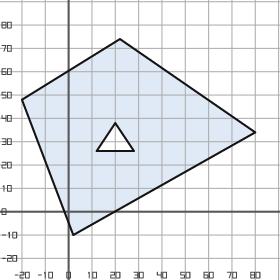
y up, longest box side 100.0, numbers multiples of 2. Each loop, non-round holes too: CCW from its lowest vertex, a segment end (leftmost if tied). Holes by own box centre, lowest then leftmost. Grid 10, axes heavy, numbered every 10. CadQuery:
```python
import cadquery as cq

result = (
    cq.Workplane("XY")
    .moveTo(2.0, -10.0)
    .lineTo(80.0, 34.0)
    .lineTo(22.0, 74.0)
    .lineTo(-20.0, 48.0)
    .close()
    .moveTo(12.0, 26.0)
    .lineTo(28.0, 26.0)
    .lineTo(20.0, 38.0)
    .close()
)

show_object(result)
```